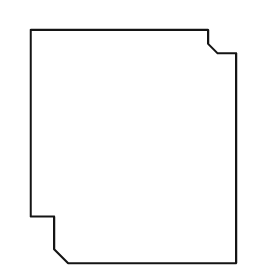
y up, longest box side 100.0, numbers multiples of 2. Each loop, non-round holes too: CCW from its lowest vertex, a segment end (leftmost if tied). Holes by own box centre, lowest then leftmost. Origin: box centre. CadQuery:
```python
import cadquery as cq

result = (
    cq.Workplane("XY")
    .moveTo(-28.0, -50.0)
    .lineTo(44.0, -50.0)
    .lineTo(44.0, 40.0)
    .lineTo(36.0, 40.0)
    .lineTo(32.0, 44.0)
    .lineTo(32.0, 50.0)
    .lineTo(-44.0, 50.0)
    .lineTo(-44.0, -30.0)
    .lineTo(-34.0, -30.0)
    .lineTo(-34.0, -44.0)
    .close()
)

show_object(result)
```